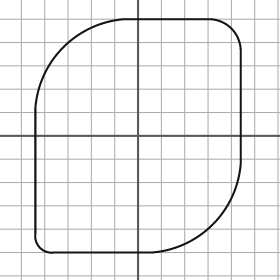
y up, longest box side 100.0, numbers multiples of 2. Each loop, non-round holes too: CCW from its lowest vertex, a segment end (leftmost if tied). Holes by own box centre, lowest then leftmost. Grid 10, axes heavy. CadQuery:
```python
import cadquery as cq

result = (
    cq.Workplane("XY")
    .moveTo(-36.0, -50.0)
    .lineTo(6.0, -50.0)
    .threePointArc((32.0, -38.0), (44.0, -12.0))
    .lineTo(44.0, 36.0)
    .threePointArc((40.0, 46.0), (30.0, 50.0))
    .lineTo(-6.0, 50.0)
    .threePointArc((-32.0, 38.0), (-44.0, 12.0))
    .lineTo(-44.0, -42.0)
    .threePointArc((-42.0, -48.0), (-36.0, -50.0))
    .close()
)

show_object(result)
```